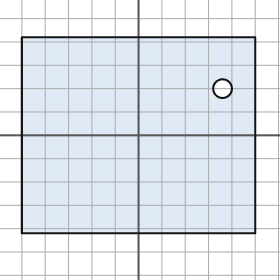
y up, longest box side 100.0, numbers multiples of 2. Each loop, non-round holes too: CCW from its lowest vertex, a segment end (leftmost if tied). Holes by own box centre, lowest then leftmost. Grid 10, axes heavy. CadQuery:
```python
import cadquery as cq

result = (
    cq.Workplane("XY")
    .moveTo(-50.0, -42.0)
    .lineTo(50.0, -42.0)
    .lineTo(50.0, 42.0)
    .lineTo(-50.0, 42.0)
    .close()
    .moveTo(36.0, 20.0)
    .circle(4.0)
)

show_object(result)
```